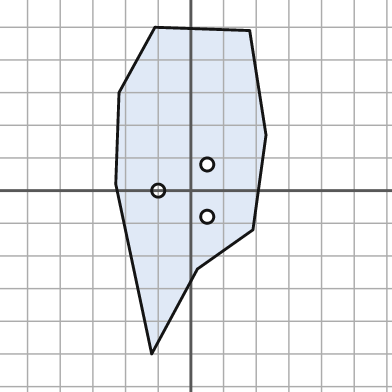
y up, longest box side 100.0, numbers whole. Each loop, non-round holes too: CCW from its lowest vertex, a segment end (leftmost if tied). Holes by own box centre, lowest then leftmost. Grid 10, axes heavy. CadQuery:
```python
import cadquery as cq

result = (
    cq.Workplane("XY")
    .moveTo(-12.0, -50.0)
    .lineTo(2.0, -24.0)
    .lineTo(19.0, -12.0)
    .lineTo(23.0, 17.0)
    .lineTo(18.0, 49.0)
    .lineTo(-11.0, 50.0)
    .lineTo(-22.0, 30.0)
    .lineTo(-23.0, 2.0)
    .close()
    .moveTo(5.0, -8.0)
    .circle(2.0)
    .moveTo(-10.0, 0.0)
    .circle(2.0)
    .moveTo(5.0, 8.0)
    .circle(2.0)
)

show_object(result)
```